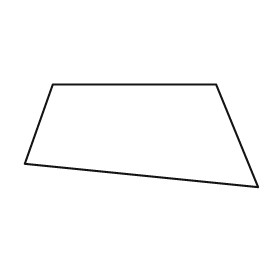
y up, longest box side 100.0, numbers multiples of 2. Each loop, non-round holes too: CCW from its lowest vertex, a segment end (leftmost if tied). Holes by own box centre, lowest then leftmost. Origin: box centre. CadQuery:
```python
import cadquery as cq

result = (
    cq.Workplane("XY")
    .moveTo(50.0, -22.0)
    .lineTo(32.0, 22.0)
    .lineTo(-38.0, 22.0)
    .lineTo(-50.0, -12.0)
    .close()
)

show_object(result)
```